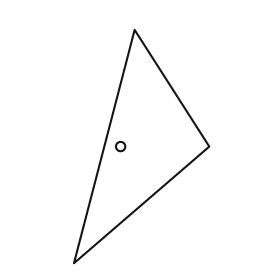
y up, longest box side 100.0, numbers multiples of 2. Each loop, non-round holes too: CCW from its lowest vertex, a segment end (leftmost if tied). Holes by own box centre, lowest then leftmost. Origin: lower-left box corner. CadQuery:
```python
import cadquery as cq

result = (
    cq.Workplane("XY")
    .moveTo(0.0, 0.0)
    .lineTo(58.0, 50.0)
    .lineTo(26.0, 100.0)
    .close()
    .moveTo(20.0, 50.0)
    .circle(2.0)
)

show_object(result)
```